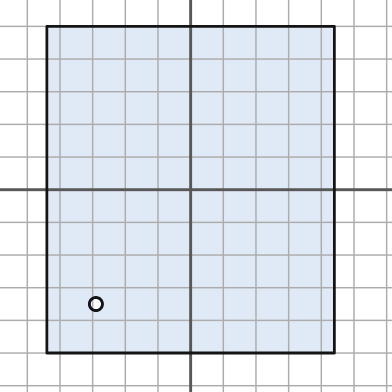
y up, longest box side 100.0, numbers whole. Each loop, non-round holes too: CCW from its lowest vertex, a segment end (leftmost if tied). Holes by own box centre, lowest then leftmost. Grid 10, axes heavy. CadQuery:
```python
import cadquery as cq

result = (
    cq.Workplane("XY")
    .moveTo(-44.0, -50.0)
    .lineTo(44.0, -50.0)
    .lineTo(44.0, 50.0)
    .lineTo(-44.0, 50.0)
    .close()
    .moveTo(-29.0, -35.0)
    .circle(2.0)
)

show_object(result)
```